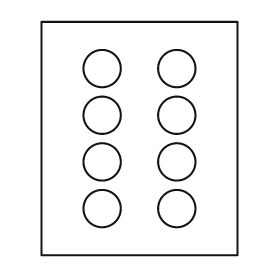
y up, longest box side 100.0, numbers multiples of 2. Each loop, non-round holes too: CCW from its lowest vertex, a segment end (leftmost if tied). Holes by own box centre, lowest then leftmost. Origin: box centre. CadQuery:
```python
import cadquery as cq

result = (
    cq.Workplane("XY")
    .moveTo(-42.0, -50.0)
    .lineTo(42.0, -50.0)
    .lineTo(42.0, 50.0)
    .lineTo(-42.0, 50.0)
    .close()
    .moveTo(-16.0, -30.0)
    .circle(8.0)
    .moveTo(16.0, -30.0)
    .circle(8.0)
    .moveTo(-16.0, -10.0)
    .circle(8.0)
    .moveTo(16.0, -10.0)
    .circle(8.0)
    .moveTo(-16.0, 10.0)
    .circle(8.0)
    .moveTo(16.0, 10.0)
    .circle(8.0)
    .moveTo(-16.0, 30.0)
    .circle(8.0)
    .moveTo(16.0, 30.0)
    .circle(8.0)
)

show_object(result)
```